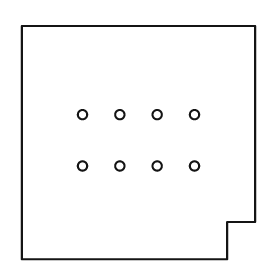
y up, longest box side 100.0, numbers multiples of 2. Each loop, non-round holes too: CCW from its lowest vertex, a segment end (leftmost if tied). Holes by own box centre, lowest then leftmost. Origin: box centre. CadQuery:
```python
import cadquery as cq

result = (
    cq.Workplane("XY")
    .moveTo(-50.0, -50.0)
    .lineTo(38.0, -50.0)
    .lineTo(38.0, -34.0)
    .lineTo(50.0, -34.0)
    .lineTo(50.0, 50.0)
    .lineTo(-50.0, 50.0)
    .close()
    .moveTo(-24.0, -10.0)
    .circle(2.0)
    .moveTo(-8.0, -10.0)
    .circle(2.0)
    .moveTo(8.0, -10.0)
    .circle(2.0)
    .moveTo(24.0, -10.0)
    .circle(2.0)
    .moveTo(-24.0, 12.0)
    .circle(2.0)
    .moveTo(-8.0, 12.0)
    .circle(2.0)
    .moveTo(8.0, 12.0)
    .circle(2.0)
    .moveTo(24.0, 12.0)
    .circle(2.0)
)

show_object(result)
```